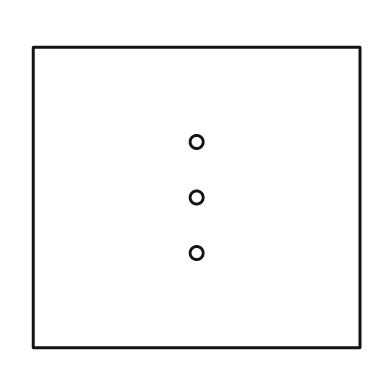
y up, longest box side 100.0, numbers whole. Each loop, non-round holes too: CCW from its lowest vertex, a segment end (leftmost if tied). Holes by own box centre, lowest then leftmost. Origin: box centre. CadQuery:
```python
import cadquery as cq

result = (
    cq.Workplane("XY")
    .moveTo(-50.0, -46.0)
    .lineTo(50.0, -46.0)
    .lineTo(50.0, 46.0)
    .lineTo(-50.0, 46.0)
    .close()
    .moveTo(0.0, -17.0)
    .circle(2.0)
    .moveTo(0.0, 0.0)
    .circle(2.0)
    .moveTo(0.0, 17.0)
    .circle(2.0)
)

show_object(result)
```